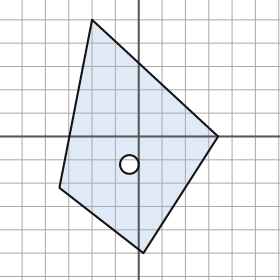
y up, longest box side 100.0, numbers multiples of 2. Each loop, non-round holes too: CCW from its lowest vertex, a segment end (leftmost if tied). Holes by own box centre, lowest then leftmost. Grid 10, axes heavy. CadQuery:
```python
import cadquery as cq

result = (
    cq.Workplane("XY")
    .moveTo(2.0, -50.0)
    .lineTo(34.0, 0.0)
    .lineTo(-20.0, 50.0)
    .lineTo(-34.0, -22.0)
    .close()
    .moveTo(-4.0, -12.0)
    .circle(4.0)
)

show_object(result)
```